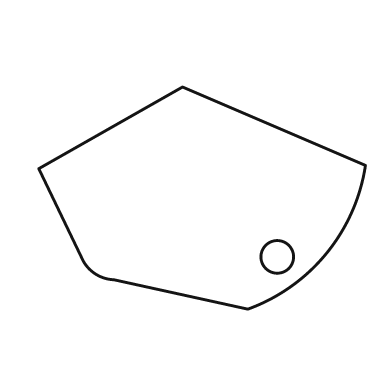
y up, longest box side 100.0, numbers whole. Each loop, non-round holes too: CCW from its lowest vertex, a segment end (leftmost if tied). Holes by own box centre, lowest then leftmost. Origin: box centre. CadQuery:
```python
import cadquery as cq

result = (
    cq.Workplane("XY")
    .moveTo(14.0, -34.0)
    .threePointArc((38.0, -17.0), (50.0, 10.0))
    .lineTo(-6.0, 34.0)
    .lineTo(-50.0, 9.0)
    .lineTo(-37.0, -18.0)
    .threePointArc((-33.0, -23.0), (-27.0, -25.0))
    .close()
    .moveTo(23.0, -18.0)
    .circle(5.0)
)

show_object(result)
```